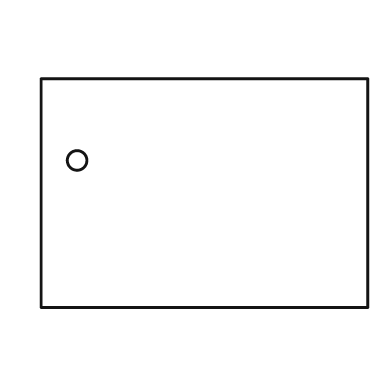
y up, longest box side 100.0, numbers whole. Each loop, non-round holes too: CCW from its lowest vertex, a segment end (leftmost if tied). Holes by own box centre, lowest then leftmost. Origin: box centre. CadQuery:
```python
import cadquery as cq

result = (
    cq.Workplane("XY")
    .moveTo(-50.0, -35.0)
    .lineTo(50.0, -35.0)
    .lineTo(50.0, 35.0)
    .lineTo(-50.0, 35.0)
    .close()
    .moveTo(-39.0, 10.0)
    .circle(3.0)
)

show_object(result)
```